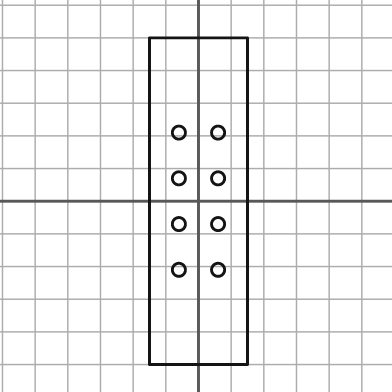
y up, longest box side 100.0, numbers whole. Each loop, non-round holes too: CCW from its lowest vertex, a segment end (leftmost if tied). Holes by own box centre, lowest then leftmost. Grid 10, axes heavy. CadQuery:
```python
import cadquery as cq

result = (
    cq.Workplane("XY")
    .moveTo(-15.0, -50.0)
    .lineTo(15.0, -50.0)
    .lineTo(15.0, 50.0)
    .lineTo(-15.0, 50.0)
    .close()
    .moveTo(-6.0, -21.0)
    .circle(2.0)
    .moveTo(6.0, -21.0)
    .circle(2.0)
    .moveTo(-6.0, -7.0)
    .circle(2.0)
    .moveTo(6.0, -7.0)
    .circle(2.0)
    .moveTo(-6.0, 7.0)
    .circle(2.0)
    .moveTo(6.0, 7.0)
    .circle(2.0)
    .moveTo(-6.0, 21.0)
    .circle(2.0)
    .moveTo(6.0, 21.0)
    .circle(2.0)
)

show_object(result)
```